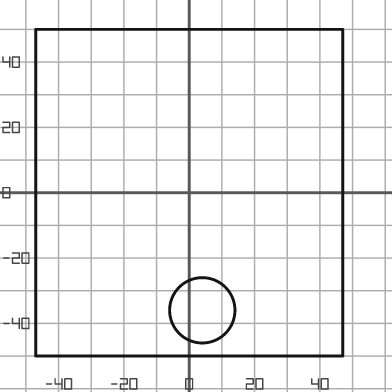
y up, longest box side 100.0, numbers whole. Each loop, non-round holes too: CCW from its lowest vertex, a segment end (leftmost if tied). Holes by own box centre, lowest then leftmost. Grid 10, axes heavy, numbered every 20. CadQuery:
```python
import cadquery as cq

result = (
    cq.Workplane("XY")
    .moveTo(-47.0, -50.0)
    .lineTo(47.0, -50.0)
    .lineTo(47.0, 50.0)
    .lineTo(-47.0, 50.0)
    .close()
    .moveTo(4.0, -36.0)
    .circle(10.0)
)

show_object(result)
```